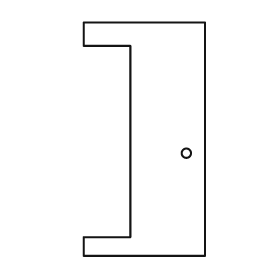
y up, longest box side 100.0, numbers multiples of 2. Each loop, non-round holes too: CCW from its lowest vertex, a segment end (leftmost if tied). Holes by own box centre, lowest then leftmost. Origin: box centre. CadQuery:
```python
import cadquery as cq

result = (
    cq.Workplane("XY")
    .moveTo(-26.0, -50.0)
    .lineTo(26.0, -50.0)
    .lineTo(26.0, 50.0)
    .lineTo(-26.0, 50.0)
    .lineTo(-26.0, 40.0)
    .lineTo(-6.0, 40.0)
    .lineTo(-6.0, -42.0)
    .lineTo(-26.0, -42.0)
    .close()
    .moveTo(18.0, -6.0)
    .circle(2.0)
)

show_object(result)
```